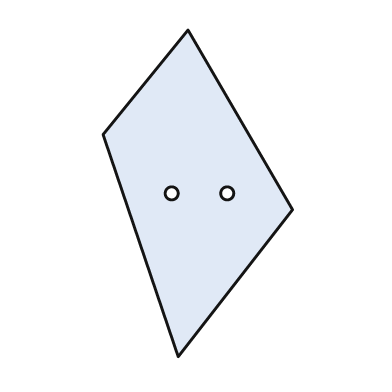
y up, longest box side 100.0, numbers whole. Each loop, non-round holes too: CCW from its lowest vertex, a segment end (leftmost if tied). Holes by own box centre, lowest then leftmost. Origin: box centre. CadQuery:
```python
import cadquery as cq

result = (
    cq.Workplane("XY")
    .moveTo(-6.0, -50.0)
    .lineTo(29.0, -5.0)
    .lineTo(-3.0, 50.0)
    .lineTo(-29.0, 18.0)
    .close()
    .moveTo(-8.0, 0.0)
    .circle(2.0)
    .moveTo(9.0, 0.0)
    .circle(2.0)
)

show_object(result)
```